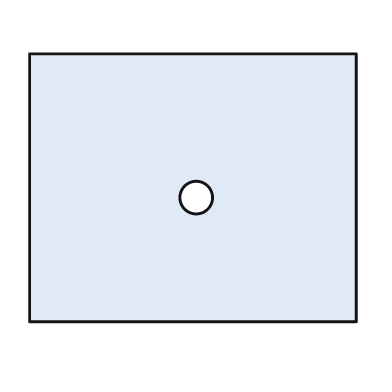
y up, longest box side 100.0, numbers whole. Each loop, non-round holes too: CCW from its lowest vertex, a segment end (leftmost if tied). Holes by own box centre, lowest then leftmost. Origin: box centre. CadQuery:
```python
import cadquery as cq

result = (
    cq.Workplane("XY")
    .moveTo(-50.0, -41.0)
    .lineTo(50.0, -41.0)
    .lineTo(50.0, 41.0)
    .lineTo(-50.0, 41.0)
    .close()
    .moveTo(1.0, -3.0)
    .circle(5.0)
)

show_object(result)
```